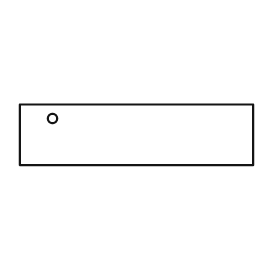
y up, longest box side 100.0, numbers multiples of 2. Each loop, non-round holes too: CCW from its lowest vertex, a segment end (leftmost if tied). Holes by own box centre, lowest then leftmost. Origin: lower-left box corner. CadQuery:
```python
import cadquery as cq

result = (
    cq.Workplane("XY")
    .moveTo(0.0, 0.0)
    .lineTo(100.0, 0.0)
    .lineTo(100.0, 26.0)
    .lineTo(0.0, 26.0)
    .close()
    .moveTo(14.0, 20.0)
    .circle(2.0)
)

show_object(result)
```